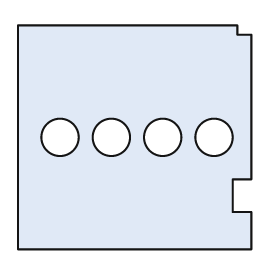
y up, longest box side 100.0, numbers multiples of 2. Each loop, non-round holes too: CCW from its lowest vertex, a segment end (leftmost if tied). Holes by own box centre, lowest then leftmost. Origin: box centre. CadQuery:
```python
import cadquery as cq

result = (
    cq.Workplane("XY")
    .moveTo(-50.0, -48.0)
    .lineTo(50.0, -48.0)
    .lineTo(50.0, -32.0)
    .lineTo(42.0, -32.0)
    .lineTo(42.0, -18.0)
    .lineTo(50.0, -18.0)
    .lineTo(50.0, 44.0)
    .lineTo(44.0, 44.0)
    .lineTo(44.0, 48.0)
    .lineTo(-50.0, 48.0)
    .close()
    .moveTo(-32.0, 0.0)
    .circle(8.0)
    .moveTo(-10.0, 0.0)
    .circle(8.0)
    .moveTo(12.0, 0.0)
    .circle(8.0)
    .moveTo(34.0, 0.0)
    .circle(8.0)
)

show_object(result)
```